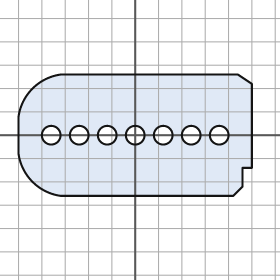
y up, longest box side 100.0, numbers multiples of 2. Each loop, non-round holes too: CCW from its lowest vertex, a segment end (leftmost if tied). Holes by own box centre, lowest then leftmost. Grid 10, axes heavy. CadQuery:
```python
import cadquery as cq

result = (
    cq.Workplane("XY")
    .moveTo(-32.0, -26.0)
    .lineTo(42.0, -26.0)
    .lineTo(46.0, -22.0)
    .lineTo(46.0, -14.0)
    .lineTo(50.0, -14.0)
    .lineTo(50.0, 22.0)
    .lineTo(44.0, 26.0)
    .lineTo(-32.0, 26.0)
    .threePointArc((-44.0, 20.0), (-50.0, 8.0))
    .lineTo(-50.0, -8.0)
    .threePointArc((-44.0, -20.0), (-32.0, -26.0))
    .close()
    .moveTo(-36.0, 0.0)
    .circle(4.0)
    .moveTo(-24.0, 0.0)
    .circle(4.0)
    .moveTo(-12.0, 0.0)
    .circle(4.0)
    .moveTo(0.0, 0.0)
    .circle(4.0)
    .moveTo(12.0, 0.0)
    .circle(4.0)
    .moveTo(24.0, 0.0)
    .circle(4.0)
    .moveTo(36.0, 0.0)
    .circle(4.0)
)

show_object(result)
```